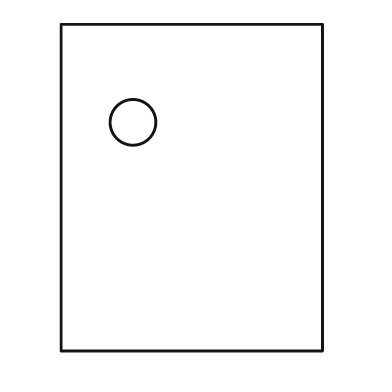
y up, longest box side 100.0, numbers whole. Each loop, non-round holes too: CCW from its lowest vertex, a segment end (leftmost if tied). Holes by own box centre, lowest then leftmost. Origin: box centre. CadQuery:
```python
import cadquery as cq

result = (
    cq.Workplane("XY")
    .moveTo(-40.0, -50.0)
    .lineTo(40.0, -50.0)
    .lineTo(40.0, 50.0)
    .lineTo(-40.0, 50.0)
    .close()
    .moveTo(-18.0, 20.0)
    .circle(7.0)
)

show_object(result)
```